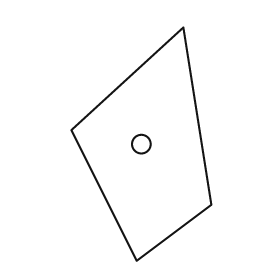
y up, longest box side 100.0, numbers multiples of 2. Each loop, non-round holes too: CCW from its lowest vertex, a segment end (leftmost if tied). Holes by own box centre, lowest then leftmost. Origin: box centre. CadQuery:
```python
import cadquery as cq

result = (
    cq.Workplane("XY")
    .moveTo(-2.0, -50.0)
    .lineTo(30.0, -26.0)
    .lineTo(18.0, 50.0)
    .lineTo(-30.0, 6.0)
    .close()
    .moveTo(0.0, 0.0)
    .circle(4.0)
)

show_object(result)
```